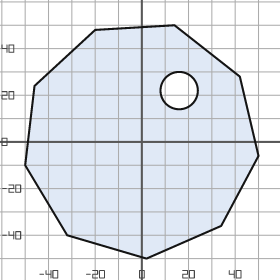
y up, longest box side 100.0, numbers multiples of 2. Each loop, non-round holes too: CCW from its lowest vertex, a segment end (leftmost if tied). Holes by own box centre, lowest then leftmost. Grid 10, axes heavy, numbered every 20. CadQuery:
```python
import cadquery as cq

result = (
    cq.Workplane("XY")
    .moveTo(2.0, -50.0)
    .lineTo(34.0, -36.0)
    .lineTo(50.0, -6.0)
    .lineTo(42.0, 28.0)
    .lineTo(14.0, 50.0)
    .lineTo(-20.0, 48.0)
    .lineTo(-46.0, 24.0)
    .lineTo(-50.0, -10.0)
    .lineTo(-32.0, -40.0)
    .close()
    .moveTo(16.0, 22.0)
    .circle(8.0)
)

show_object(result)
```